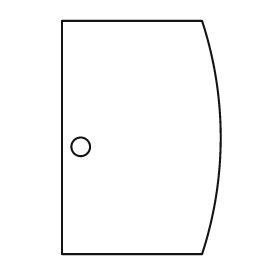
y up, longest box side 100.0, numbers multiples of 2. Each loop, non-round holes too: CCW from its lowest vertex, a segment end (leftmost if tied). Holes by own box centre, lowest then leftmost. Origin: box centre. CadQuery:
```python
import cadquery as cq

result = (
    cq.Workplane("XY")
    .moveTo(-34.0, -50.0)
    .lineTo(26.0, -50.0)
    .threePointArc((34.0, 0.0), (26.0, 50.0))
    .lineTo(-34.0, 50.0)
    .close()
    .moveTo(-26.0, -4.0)
    .circle(4.0)
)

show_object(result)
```